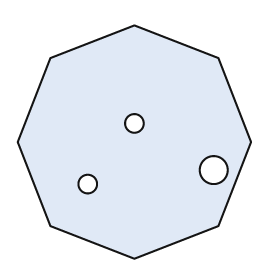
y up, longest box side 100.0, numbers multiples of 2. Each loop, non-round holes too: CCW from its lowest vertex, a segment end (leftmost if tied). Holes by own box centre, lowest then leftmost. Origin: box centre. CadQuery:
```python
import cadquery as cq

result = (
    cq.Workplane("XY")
    .moveTo(0.0, -50.0)
    .lineTo(36.0, -36.0)
    .lineTo(50.0, 0.0)
    .lineTo(36.0, 36.0)
    .lineTo(0.0, 50.0)
    .lineTo(-36.0, 36.0)
    .lineTo(-50.0, 0.0)
    .lineTo(-36.0, -36.0)
    .close()
    .moveTo(-20.0, -18.0)
    .circle(4.0)
    .moveTo(34.0, -12.0)
    .circle(6.0)
    .moveTo(0.0, 8.0)
    .circle(4.0)
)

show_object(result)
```